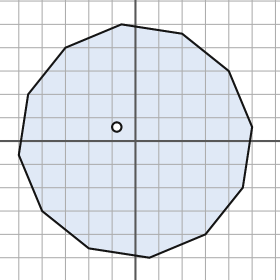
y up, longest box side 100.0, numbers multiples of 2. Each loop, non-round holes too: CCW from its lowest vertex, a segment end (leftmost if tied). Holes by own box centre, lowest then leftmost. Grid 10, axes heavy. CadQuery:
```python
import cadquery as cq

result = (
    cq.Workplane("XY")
    .moveTo(6.0, -50.0)
    .lineTo(30.0, -40.0)
    .lineTo(46.0, -20.0)
    .lineTo(50.0, 6.0)
    .lineTo(40.0, 30.0)
    .lineTo(20.0, 46.0)
    .lineTo(-6.0, 50.0)
    .lineTo(-30.0, 40.0)
    .lineTo(-46.0, 20.0)
    .lineTo(-50.0, -6.0)
    .lineTo(-40.0, -30.0)
    .lineTo(-20.0, -46.0)
    .close()
    .moveTo(-8.0, 6.0)
    .circle(2.0)
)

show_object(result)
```